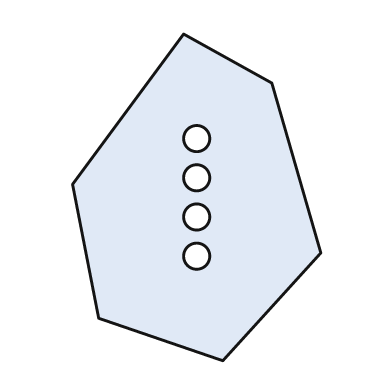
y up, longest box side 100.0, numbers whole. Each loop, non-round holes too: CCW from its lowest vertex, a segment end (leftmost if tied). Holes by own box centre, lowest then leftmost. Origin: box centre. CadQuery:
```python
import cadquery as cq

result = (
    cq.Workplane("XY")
    .moveTo(8.0, -50.0)
    .lineTo(38.0, -17.0)
    .lineTo(23.0, 35.0)
    .lineTo(-4.0, 50.0)
    .lineTo(-38.0, 4.0)
    .lineTo(-30.0, -37.0)
    .close()
    .moveTo(0.0, -18.0)
    .circle(4.0)
    .moveTo(0.0, -6.0)
    .circle(4.0)
    .moveTo(0.0, 6.0)
    .circle(4.0)
    .moveTo(0.0, 18.0)
    .circle(4.0)
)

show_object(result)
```